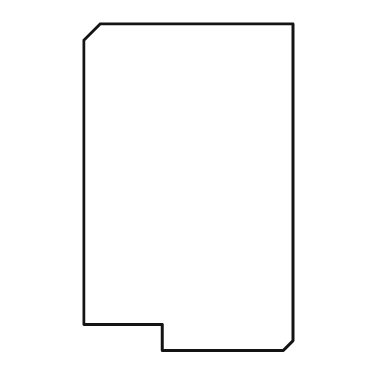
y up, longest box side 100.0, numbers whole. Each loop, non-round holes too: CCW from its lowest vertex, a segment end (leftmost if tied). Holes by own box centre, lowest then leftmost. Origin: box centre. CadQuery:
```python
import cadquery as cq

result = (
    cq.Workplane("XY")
    .moveTo(-8.0, -50.0)
    .lineTo(29.0, -50.0)
    .lineTo(32.0, -47.0)
    .lineTo(32.0, 50.0)
    .lineTo(-27.0, 50.0)
    .lineTo(-32.0, 45.0)
    .lineTo(-32.0, -42.0)
    .lineTo(-8.0, -42.0)
    .close()
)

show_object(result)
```